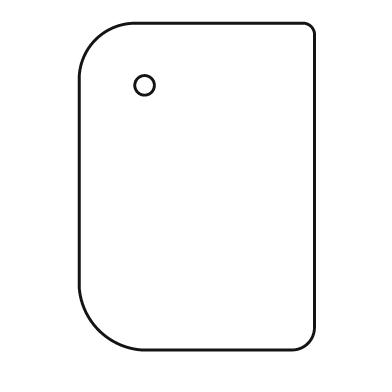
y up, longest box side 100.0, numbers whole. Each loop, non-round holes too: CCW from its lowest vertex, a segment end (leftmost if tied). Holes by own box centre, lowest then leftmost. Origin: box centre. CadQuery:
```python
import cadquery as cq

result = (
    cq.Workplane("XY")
    .moveTo(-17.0, -50.0)
    .lineTo(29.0, -50.0)
    .threePointArc((34.0, -48.0), (36.0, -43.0))
    .lineTo(36.0, 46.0)
    .threePointArc((35.0, 49.0), (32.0, 50.0))
    .lineTo(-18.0, 50.0)
    .threePointArc((-31.0, 45.0), (-36.0, 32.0))
    .lineTo(-36.0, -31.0)
    .threePointArc((-30.0, -44.0), (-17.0, -50.0))
    .close()
    .moveTo(-16.0, 31.0)
    .circle(3.0)
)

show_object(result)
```